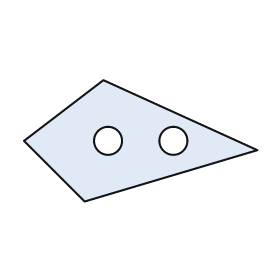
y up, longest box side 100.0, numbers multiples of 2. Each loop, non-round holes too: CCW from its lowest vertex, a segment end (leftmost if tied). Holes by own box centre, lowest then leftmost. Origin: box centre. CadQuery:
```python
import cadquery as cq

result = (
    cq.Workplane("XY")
    .moveTo(-24.0, -26.0)
    .lineTo(50.0, -4.0)
    .lineTo(-16.0, 26.0)
    .lineTo(-50.0, 0.0)
    .close()
    .moveTo(-14.0, 0.0)
    .circle(6.0)
    .moveTo(14.0, 0.0)
    .circle(6.0)
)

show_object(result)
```